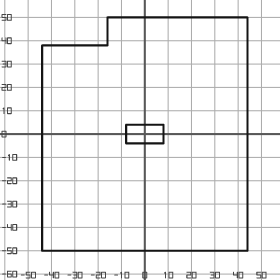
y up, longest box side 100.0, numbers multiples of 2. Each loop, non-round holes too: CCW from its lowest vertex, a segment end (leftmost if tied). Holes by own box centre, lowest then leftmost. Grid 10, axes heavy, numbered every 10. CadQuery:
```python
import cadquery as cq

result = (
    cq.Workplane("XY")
    .moveTo(-44.0, -50.0)
    .lineTo(44.0, -50.0)
    .lineTo(44.0, 50.0)
    .lineTo(-16.0, 50.0)
    .lineTo(-16.0, 38.0)
    .lineTo(-44.0, 38.0)
    .close()
    .moveTo(-8.0, -4.0)
    .lineTo(8.0, -4.0)
    .lineTo(8.0, 4.0)
    .lineTo(-8.0, 4.0)
    .close()
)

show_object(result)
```